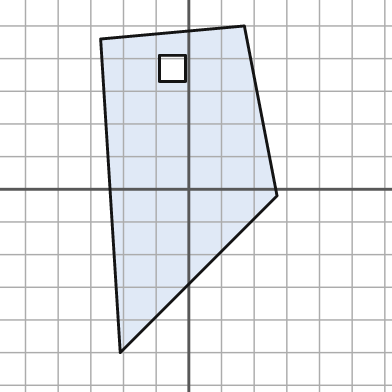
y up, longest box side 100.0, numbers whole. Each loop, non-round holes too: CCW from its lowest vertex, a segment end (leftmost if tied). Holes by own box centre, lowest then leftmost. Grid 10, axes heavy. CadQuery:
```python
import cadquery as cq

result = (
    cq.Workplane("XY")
    .moveTo(-21.0, -50.0)
    .lineTo(27.0, -2.0)
    .lineTo(17.0, 50.0)
    .lineTo(-27.0, 46.0)
    .close()
    .moveTo(-9.0, 33.0)
    .lineTo(-1.0, 33.0)
    .lineTo(-1.0, 41.0)
    .lineTo(-9.0, 41.0)
    .close()
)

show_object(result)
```